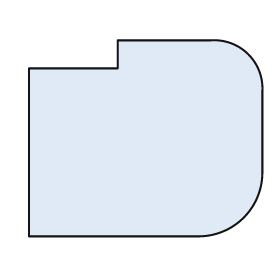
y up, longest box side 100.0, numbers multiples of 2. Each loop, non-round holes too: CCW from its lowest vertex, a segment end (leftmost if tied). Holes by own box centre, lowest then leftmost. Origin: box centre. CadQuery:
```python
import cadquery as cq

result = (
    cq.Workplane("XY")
    .moveTo(-50.0, -42.0)
    .lineTo(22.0, -42.0)
    .threePointArc((42.0, -34.0), (50.0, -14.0))
    .lineTo(50.0, 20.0)
    .threePointArc((44.0, 36.0), (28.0, 42.0))
    .lineTo(-12.0, 42.0)
    .lineTo(-12.0, 30.0)
    .lineTo(-50.0, 30.0)
    .close()
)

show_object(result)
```